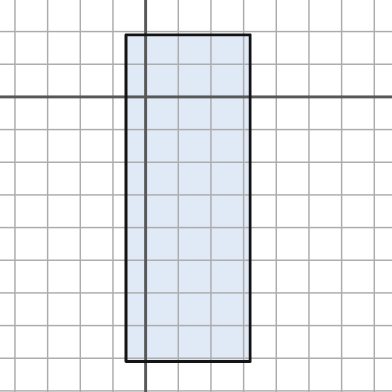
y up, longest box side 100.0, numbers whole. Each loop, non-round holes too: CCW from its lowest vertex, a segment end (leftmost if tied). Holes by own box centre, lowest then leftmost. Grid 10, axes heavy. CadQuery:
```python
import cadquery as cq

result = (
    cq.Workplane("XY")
    .moveTo(-6.0, -81.0)
    .lineTo(32.0, -81.0)
    .lineTo(32.0, 19.0)
    .lineTo(-6.0, 19.0)
    .close()
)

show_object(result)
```